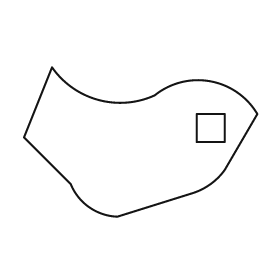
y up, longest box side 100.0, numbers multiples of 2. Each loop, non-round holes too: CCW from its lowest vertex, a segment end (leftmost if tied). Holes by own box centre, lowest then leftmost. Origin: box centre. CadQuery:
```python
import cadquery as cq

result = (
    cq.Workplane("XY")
    .moveTo(-10.0, -32.0)
    .lineTo(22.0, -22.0)
    .threePointArc((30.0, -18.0), (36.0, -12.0))
    .lineTo(50.0, 12.0)
    .threePointArc((30.0, 26.0), (6.0, 20.0))
    .threePointArc((-18.0, 18.0), (-38.0, 32.0))
    .lineTo(-50.0, 2.0)
    .lineTo(-30.0, -18.0)
    .threePointArc((-22.0, -28.0), (-10.0, -32.0))
    .close()
    .moveTo(24.0, 0.0)
    .lineTo(36.0, 0.0)
    .lineTo(36.0, 12.0)
    .lineTo(24.0, 12.0)
    .close()
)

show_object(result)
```